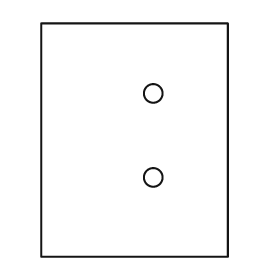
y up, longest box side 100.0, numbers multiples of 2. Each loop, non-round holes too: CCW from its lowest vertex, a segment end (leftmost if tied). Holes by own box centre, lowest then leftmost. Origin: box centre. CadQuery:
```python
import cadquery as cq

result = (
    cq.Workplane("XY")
    .moveTo(-40.0, -50.0)
    .lineTo(40.0, -50.0)
    .lineTo(40.0, 50.0)
    .lineTo(-40.0, 50.0)
    .close()
    .moveTo(8.0, -16.0)
    .circle(4.0)
    .moveTo(8.0, 20.0)
    .circle(4.0)
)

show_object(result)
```